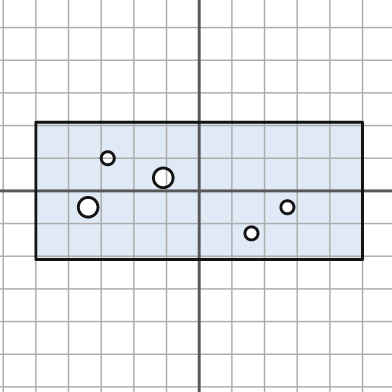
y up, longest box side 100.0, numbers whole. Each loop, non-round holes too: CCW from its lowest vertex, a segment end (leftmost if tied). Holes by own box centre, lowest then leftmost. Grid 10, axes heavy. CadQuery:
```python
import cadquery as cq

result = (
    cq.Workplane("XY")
    .moveTo(-50.0, -21.0)
    .lineTo(50.0, -21.0)
    .lineTo(50.0, 21.0)
    .lineTo(-50.0, 21.0)
    .close()
    .moveTo(16.0, -13.0)
    .circle(2.0)
    .moveTo(-34.0, -5.0)
    .circle(3.0)
    .moveTo(27.0, -5.0)
    .circle(2.0)
    .moveTo(-11.0, 4.0)
    .circle(3.0)
    .moveTo(-28.0, 10.0)
    .circle(2.0)
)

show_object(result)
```